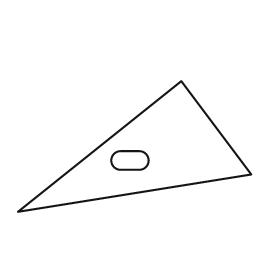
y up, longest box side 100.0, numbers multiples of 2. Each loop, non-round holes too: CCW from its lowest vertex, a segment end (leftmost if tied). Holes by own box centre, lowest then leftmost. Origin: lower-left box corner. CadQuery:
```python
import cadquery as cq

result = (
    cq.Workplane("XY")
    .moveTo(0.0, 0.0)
    .lineTo(100.0, 16.0)
    .lineTo(70.0, 56.0)
    .close()
    .moveTo(44.0, 18.0)
    .lineTo(52.0, 18.0)
    .threePointArc((56.0, 22.0), (52.0, 26.0))
    .lineTo(44.0, 26.0)
    .threePointArc((40.0, 22.0), (44.0, 18.0))
    .close()
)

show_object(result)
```